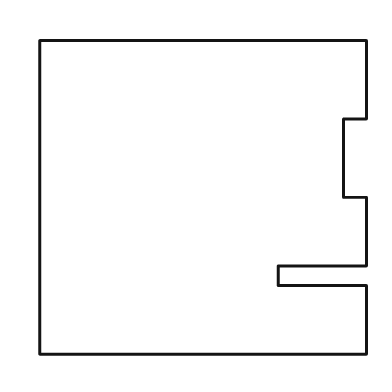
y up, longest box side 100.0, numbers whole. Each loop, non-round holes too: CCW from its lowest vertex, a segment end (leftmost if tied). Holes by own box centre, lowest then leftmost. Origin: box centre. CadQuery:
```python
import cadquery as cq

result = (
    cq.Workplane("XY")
    .moveTo(-50.0, -48.0)
    .lineTo(50.0, -48.0)
    .lineTo(50.0, -27.0)
    .lineTo(23.0, -27.0)
    .lineTo(23.0, -21.0)
    .lineTo(50.0, -21.0)
    .lineTo(50.0, 0.0)
    .lineTo(43.0, 0.0)
    .lineTo(43.0, 24.0)
    .lineTo(50.0, 24.0)
    .lineTo(50.0, 48.0)
    .lineTo(-50.0, 48.0)
    .close()
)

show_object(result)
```